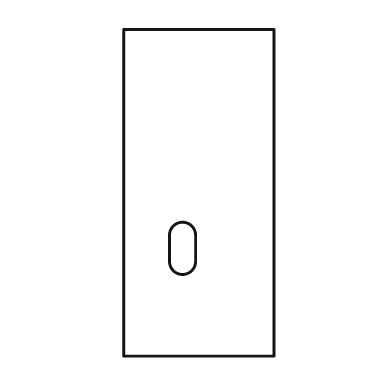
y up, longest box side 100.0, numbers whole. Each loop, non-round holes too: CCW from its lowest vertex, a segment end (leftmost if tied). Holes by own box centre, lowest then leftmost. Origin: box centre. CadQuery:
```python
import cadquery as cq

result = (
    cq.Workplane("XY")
    .moveTo(-23.0, -50.0)
    .lineTo(23.0, -50.0)
    .lineTo(23.0, 50.0)
    .lineTo(-23.0, 50.0)
    .close()
    .moveTo(-9.0, -21.0)
    .threePointArc((-5.0, -25.0), (-1.0, -21.0))
    .lineTo(-1.0, -13.0)
    .threePointArc((-5.0, -9.0), (-9.0, -13.0))
    .close()
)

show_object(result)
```